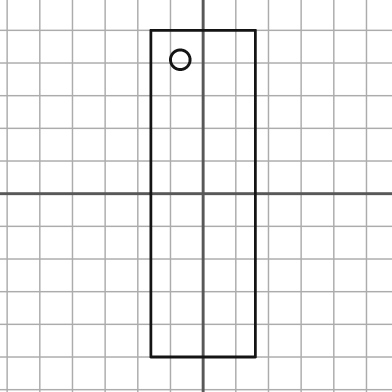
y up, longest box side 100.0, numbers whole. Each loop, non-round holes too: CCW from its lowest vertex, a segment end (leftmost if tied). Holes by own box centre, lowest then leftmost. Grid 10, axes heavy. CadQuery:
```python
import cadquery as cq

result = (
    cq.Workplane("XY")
    .moveTo(-16.0, -50.0)
    .lineTo(16.0, -50.0)
    .lineTo(16.0, 50.0)
    .lineTo(-16.0, 50.0)
    .close()
    .moveTo(-7.0, 41.0)
    .circle(3.0)
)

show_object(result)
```